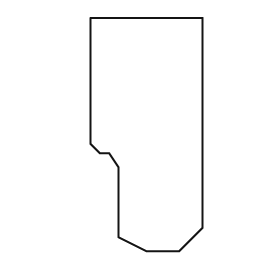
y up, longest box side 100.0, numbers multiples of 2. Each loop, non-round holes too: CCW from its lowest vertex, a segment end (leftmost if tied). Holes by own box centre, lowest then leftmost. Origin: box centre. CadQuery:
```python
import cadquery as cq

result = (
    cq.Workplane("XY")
    .moveTo(0.0, -50.0)
    .lineTo(14.0, -50.0)
    .lineTo(24.0, -40.0)
    .lineTo(24.0, 50.0)
    .lineTo(-24.0, 50.0)
    .lineTo(-24.0, -4.0)
    .lineTo(-20.0, -8.0)
    .lineTo(-16.0, -8.0)
    .lineTo(-12.0, -14.0)
    .lineTo(-12.0, -44.0)
    .close()
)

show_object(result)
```